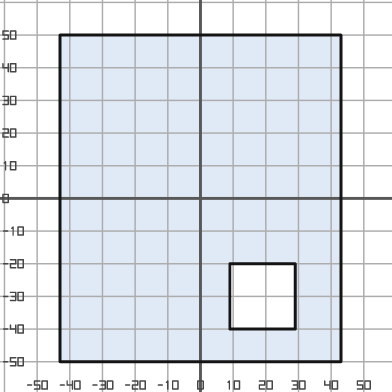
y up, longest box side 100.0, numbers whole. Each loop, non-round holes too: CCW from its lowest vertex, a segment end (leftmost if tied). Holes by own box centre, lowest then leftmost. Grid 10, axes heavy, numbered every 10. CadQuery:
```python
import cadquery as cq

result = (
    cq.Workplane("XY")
    .moveTo(-43.0, -50.0)
    .lineTo(43.0, -50.0)
    .lineTo(43.0, 50.0)
    .lineTo(-43.0, 50.0)
    .close()
    .moveTo(9.0, -40.0)
    .lineTo(29.0, -40.0)
    .lineTo(29.0, -20.0)
    .lineTo(9.0, -20.0)
    .close()
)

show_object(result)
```